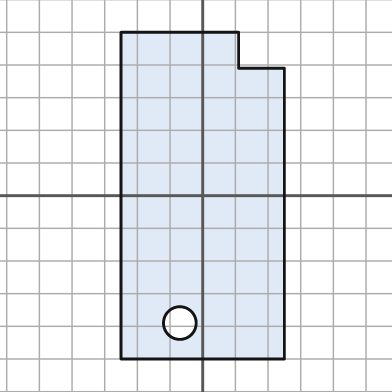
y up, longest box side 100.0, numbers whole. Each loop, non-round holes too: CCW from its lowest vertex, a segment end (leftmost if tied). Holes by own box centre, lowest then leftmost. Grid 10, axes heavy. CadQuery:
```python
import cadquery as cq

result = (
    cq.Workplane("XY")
    .moveTo(-25.0, -50.0)
    .lineTo(25.0, -50.0)
    .lineTo(25.0, 39.0)
    .lineTo(11.0, 39.0)
    .lineTo(11.0, 50.0)
    .lineTo(-25.0, 50.0)
    .close()
    .moveTo(-7.0, -39.0)
    .circle(5.0)
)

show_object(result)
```